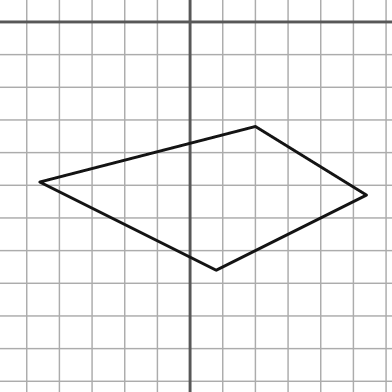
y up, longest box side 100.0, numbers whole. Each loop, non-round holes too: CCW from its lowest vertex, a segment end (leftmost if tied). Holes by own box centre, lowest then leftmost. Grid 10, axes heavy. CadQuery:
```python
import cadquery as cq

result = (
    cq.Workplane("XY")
    .moveTo(8.0, -76.0)
    .lineTo(54.0, -53.0)
    .lineTo(20.0, -32.0)
    .lineTo(-46.0, -49.0)
    .close()
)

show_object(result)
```